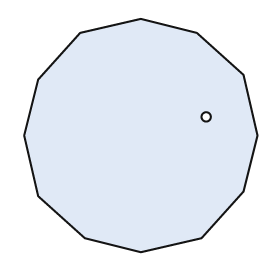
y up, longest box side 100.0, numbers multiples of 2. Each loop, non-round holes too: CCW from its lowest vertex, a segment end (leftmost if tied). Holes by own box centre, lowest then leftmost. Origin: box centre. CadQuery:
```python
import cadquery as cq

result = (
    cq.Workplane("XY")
    .moveTo(0.0, -50.0)
    .lineTo(26.0, -44.0)
    .lineTo(44.0, -24.0)
    .lineTo(50.0, 0.0)
    .lineTo(44.0, 26.0)
    .lineTo(24.0, 44.0)
    .lineTo(0.0, 50.0)
    .lineTo(-26.0, 44.0)
    .lineTo(-44.0, 24.0)
    .lineTo(-50.0, 0.0)
    .lineTo(-44.0, -26.0)
    .lineTo(-24.0, -44.0)
    .close()
    .moveTo(28.0, 8.0)
    .circle(2.0)
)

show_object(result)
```